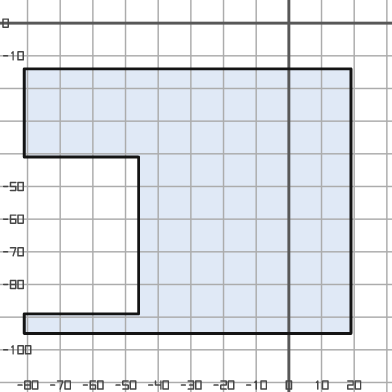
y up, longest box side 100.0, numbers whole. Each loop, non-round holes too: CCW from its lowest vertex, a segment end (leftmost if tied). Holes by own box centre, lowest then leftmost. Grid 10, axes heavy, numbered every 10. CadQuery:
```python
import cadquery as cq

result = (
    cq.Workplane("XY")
    .moveTo(-81.0, -95.0)
    .lineTo(19.0, -95.0)
    .lineTo(19.0, -14.0)
    .lineTo(-81.0, -14.0)
    .lineTo(-81.0, -41.0)
    .lineTo(-46.0, -41.0)
    .lineTo(-46.0, -89.0)
    .lineTo(-81.0, -89.0)
    .close()
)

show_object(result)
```